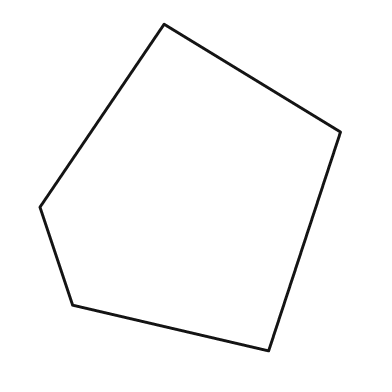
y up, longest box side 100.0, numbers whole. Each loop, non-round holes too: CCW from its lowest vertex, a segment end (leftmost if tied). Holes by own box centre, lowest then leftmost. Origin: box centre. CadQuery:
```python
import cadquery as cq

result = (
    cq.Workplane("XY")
    .moveTo(24.0, -50.0)
    .lineTo(46.0, 17.0)
    .lineTo(-8.0, 50.0)
    .lineTo(-46.0, -6.0)
    .lineTo(-36.0, -36.0)
    .close()
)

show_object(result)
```